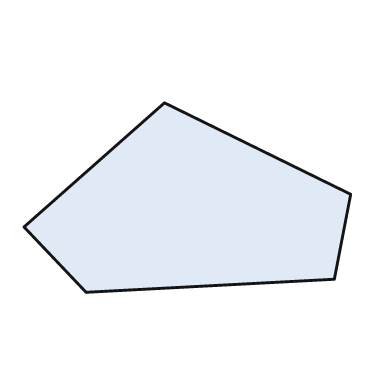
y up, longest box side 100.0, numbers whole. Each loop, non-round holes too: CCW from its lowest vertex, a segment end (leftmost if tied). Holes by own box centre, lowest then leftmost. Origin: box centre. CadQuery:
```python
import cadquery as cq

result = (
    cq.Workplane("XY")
    .moveTo(-31.0, -29.0)
    .lineTo(45.0, -25.0)
    .lineTo(50.0, 1.0)
    .lineTo(-7.0, 29.0)
    .lineTo(-50.0, -9.0)
    .close()
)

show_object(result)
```